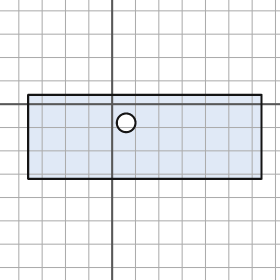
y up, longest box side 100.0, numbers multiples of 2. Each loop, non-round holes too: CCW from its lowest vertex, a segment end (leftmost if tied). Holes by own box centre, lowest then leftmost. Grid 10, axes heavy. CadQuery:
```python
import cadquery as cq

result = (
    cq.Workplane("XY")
    .moveTo(-36.0, -32.0)
    .lineTo(64.0, -32.0)
    .lineTo(64.0, 4.0)
    .lineTo(-36.0, 4.0)
    .close()
    .moveTo(6.0, -8.0)
    .circle(4.0)
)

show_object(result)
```